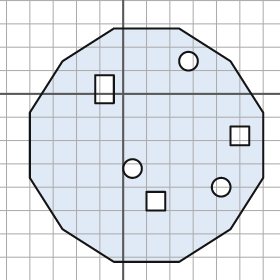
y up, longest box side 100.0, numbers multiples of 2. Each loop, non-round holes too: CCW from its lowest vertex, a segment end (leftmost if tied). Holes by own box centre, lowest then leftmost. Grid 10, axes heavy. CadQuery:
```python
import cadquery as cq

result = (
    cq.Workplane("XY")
    .moveTo(-4.0, -72.0)
    .lineTo(24.0, -72.0)
    .lineTo(46.0, -58.0)
    .lineTo(60.0, -36.0)
    .lineTo(60.0, -8.0)
    .lineTo(46.0, 14.0)
    .lineTo(24.0, 28.0)
    .lineTo(-4.0, 28.0)
    .lineTo(-26.0, 14.0)
    .lineTo(-40.0, -8.0)
    .lineTo(-40.0, -36.0)
    .lineTo(-26.0, -58.0)
    .close()
    .moveTo(10.0, -50.0)
    .lineTo(18.0, -50.0)
    .lineTo(18.0, -42.0)
    .lineTo(10.0, -42.0)
    .close()
    .moveTo(42.0, -40.0)
    .circle(4.0)
    .moveTo(4.0, -32.0)
    .circle(4.0)
    .moveTo(46.0, -22.0)
    .lineTo(54.0, -22.0)
    .lineTo(54.0, -14.0)
    .lineTo(46.0, -14.0)
    .close()
    .moveTo(-12.0, -4.0)
    .lineTo(-4.0, -4.0)
    .lineTo(-4.0, 8.0)
    .lineTo(-12.0, 8.0)
    .close()
    .moveTo(28.0, 14.0)
    .circle(4.0)
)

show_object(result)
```